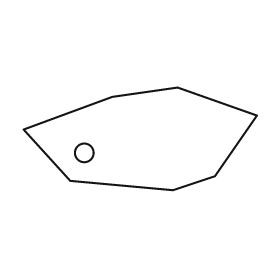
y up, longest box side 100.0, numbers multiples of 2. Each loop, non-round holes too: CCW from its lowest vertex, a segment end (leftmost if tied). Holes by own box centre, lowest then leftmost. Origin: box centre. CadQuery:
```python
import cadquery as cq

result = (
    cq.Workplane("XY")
    .moveTo(14.0, -22.0)
    .lineTo(32.0, -16.0)
    .lineTo(50.0, 10.0)
    .lineTo(16.0, 22.0)
    .lineTo(-12.0, 18.0)
    .lineTo(-50.0, 4.0)
    .lineTo(-30.0, -18.0)
    .close()
    .moveTo(-24.0, -6.0)
    .circle(4.0)
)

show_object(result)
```